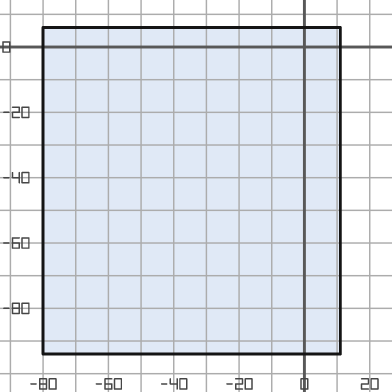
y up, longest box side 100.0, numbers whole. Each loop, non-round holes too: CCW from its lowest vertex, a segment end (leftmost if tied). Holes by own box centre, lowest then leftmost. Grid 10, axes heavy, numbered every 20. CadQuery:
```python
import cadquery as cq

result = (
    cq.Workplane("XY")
    .moveTo(-80.0, -94.0)
    .lineTo(11.0, -94.0)
    .lineTo(11.0, 6.0)
    .lineTo(-80.0, 6.0)
    .close()
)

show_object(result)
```